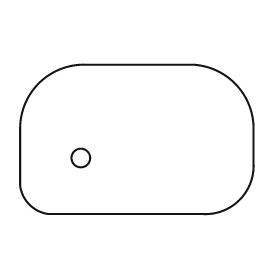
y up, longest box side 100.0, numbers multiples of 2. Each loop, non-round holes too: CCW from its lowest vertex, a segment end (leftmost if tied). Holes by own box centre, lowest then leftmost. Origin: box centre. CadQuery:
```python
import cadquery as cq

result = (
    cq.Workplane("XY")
    .moveTo(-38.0, -32.0)
    .lineTo(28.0, -32.0)
    .threePointArc((44.0, -26.0), (50.0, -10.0))
    .lineTo(50.0, 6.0)
    .threePointArc((42.0, 24.0), (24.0, 32.0))
    .lineTo(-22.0, 32.0)
    .threePointArc((-42.0, 24.0), (-50.0, 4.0))
    .lineTo(-50.0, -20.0)
    .threePointArc((-46.0, -28.0), (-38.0, -32.0))
    .close()
    .moveTo(-24.0, -8.0)
    .circle(4.0)
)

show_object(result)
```